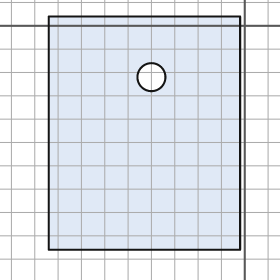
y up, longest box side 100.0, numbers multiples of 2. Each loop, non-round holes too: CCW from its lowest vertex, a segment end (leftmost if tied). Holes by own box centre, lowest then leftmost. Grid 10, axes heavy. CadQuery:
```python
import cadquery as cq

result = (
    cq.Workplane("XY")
    .moveTo(-84.0, -96.0)
    .lineTo(-2.0, -96.0)
    .lineTo(-2.0, 4.0)
    .lineTo(-84.0, 4.0)
    .close()
    .moveTo(-40.0, -22.0)
    .circle(6.0)
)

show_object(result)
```